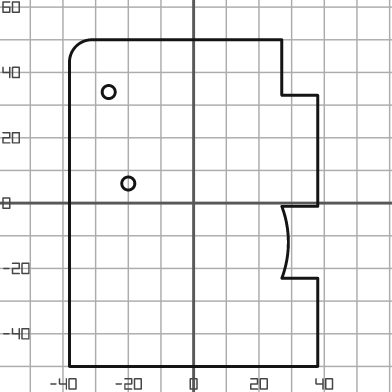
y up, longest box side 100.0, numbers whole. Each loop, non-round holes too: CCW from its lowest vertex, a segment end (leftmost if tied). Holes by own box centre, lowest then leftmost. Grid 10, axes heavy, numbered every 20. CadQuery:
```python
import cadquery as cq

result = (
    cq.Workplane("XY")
    .moveTo(-38.0, -50.0)
    .lineTo(38.0, -50.0)
    .lineTo(38.0, -23.0)
    .lineTo(27.0, -23.0)
    .threePointArc((29.0, -12.0), (27.0, -1.0))
    .lineTo(38.0, -1.0)
    .lineTo(38.0, 33.0)
    .lineTo(27.0, 33.0)
    .lineTo(27.0, 50.0)
    .lineTo(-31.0, 50.0)
    .threePointArc((-36.0, 48.0), (-38.0, 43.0))
    .close()
    .moveTo(-20.0, 6.0)
    .circle(2.0)
    .moveTo(-26.0, 34.0)
    .circle(2.0)
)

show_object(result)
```